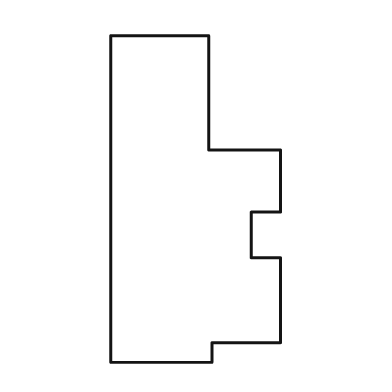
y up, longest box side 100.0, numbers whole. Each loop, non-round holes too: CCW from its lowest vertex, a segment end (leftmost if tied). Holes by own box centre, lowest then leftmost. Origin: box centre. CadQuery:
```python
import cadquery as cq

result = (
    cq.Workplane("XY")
    .moveTo(-26.0, -50.0)
    .lineTo(5.0, -50.0)
    .lineTo(5.0, -44.0)
    .lineTo(26.0, -44.0)
    .lineTo(26.0, -18.0)
    .lineTo(17.0, -18.0)
    .lineTo(17.0, -4.0)
    .lineTo(26.0, -4.0)
    .lineTo(26.0, 15.0)
    .lineTo(4.0, 15.0)
    .lineTo(4.0, 50.0)
    .lineTo(-26.0, 50.0)
    .close()
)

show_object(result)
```